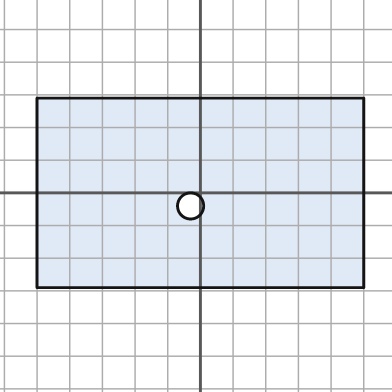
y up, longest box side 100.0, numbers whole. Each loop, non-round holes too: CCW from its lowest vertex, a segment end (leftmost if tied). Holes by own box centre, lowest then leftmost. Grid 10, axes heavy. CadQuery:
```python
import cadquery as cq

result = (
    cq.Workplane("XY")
    .moveTo(-50.0, -29.0)
    .lineTo(50.0, -29.0)
    .lineTo(50.0, 29.0)
    .lineTo(-50.0, 29.0)
    .close()
    .moveTo(-3.0, -4.0)
    .circle(4.0)
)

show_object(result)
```